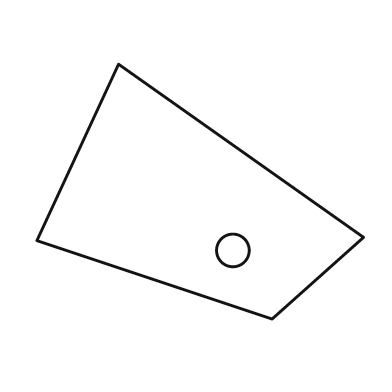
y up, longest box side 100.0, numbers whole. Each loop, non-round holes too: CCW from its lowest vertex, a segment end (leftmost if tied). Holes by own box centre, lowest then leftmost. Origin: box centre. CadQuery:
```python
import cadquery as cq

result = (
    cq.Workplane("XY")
    .moveTo(22.0, -39.0)
    .lineTo(50.0, -14.0)
    .lineTo(-25.0, 39.0)
    .lineTo(-50.0, -15.0)
    .close()
    .moveTo(10.0, -18.0)
    .circle(5.0)
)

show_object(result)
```